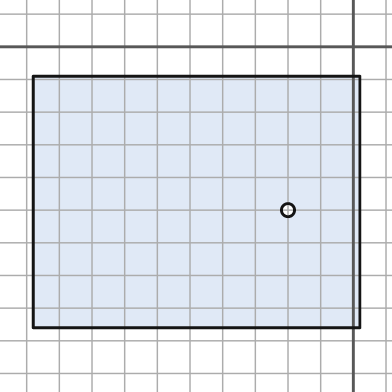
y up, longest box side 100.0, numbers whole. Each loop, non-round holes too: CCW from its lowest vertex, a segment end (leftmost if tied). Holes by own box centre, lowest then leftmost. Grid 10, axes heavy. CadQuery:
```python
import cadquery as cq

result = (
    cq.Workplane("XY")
    .moveTo(-98.0, -86.0)
    .lineTo(2.0, -86.0)
    .lineTo(2.0, -9.0)
    .lineTo(-98.0, -9.0)
    .close()
    .moveTo(-20.0, -50.0)
    .circle(2.0)
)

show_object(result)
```